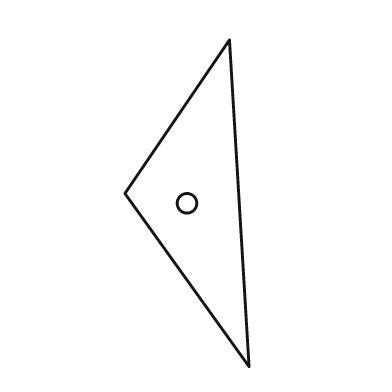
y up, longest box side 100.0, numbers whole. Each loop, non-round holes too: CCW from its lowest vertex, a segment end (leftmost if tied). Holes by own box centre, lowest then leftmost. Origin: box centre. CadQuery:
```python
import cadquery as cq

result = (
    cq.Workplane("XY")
    .moveTo(19.0, -50.0)
    .lineTo(13.0, 50.0)
    .lineTo(-19.0, 3.0)
    .close()
    .moveTo(0.0, 0.0)
    .circle(3.0)
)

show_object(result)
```